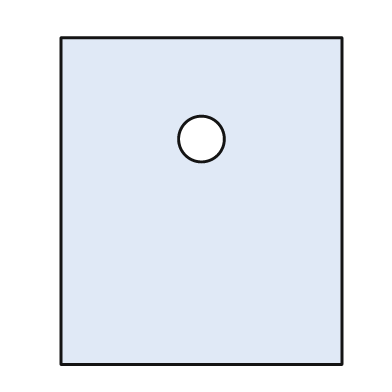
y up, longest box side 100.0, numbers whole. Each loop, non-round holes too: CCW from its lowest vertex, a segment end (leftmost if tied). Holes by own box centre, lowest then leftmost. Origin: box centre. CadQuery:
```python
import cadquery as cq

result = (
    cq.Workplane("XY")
    .moveTo(-43.0, -50.0)
    .lineTo(43.0, -50.0)
    .lineTo(43.0, 50.0)
    .lineTo(-43.0, 50.0)
    .close()
    .moveTo(0.0, 19.0)
    .circle(7.0)
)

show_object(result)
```